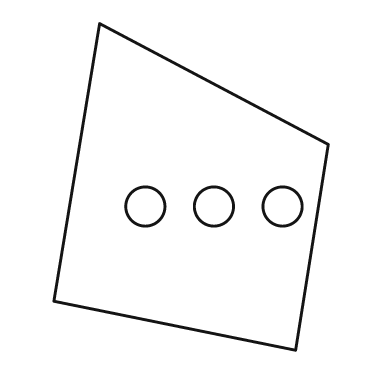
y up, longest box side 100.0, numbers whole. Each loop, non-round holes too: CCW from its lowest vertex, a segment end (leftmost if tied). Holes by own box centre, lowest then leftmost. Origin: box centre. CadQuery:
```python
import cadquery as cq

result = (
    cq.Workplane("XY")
    .moveTo(32.0, -50.0)
    .lineTo(42.0, 13.0)
    .lineTo(-28.0, 50.0)
    .lineTo(-42.0, -35.0)
    .close()
    .moveTo(-14.0, -6.0)
    .circle(6.0)
    .moveTo(7.0, -6.0)
    .circle(6.0)
    .moveTo(28.0, -6.0)
    .circle(6.0)
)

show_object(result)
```